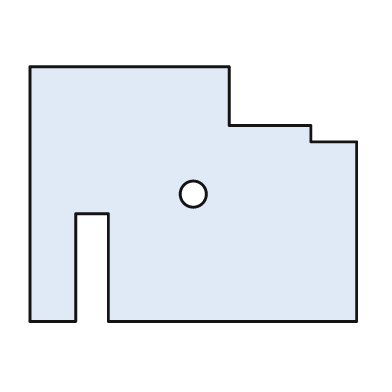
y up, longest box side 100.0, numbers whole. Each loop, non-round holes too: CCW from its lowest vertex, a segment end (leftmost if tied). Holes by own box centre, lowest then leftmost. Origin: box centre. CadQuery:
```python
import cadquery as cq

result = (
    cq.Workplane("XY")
    .moveTo(-50.0, -39.0)
    .lineTo(-36.0, -39.0)
    .lineTo(-36.0, -6.0)
    .lineTo(-26.0, -6.0)
    .lineTo(-26.0, -39.0)
    .lineTo(50.0, -39.0)
    .lineTo(50.0, 16.0)
    .lineTo(36.0, 16.0)
    .lineTo(36.0, 21.0)
    .lineTo(11.0, 21.0)
    .lineTo(11.0, 39.0)
    .lineTo(-50.0, 39.0)
    .close()
    .moveTo(0.0, 0.0)
    .circle(4.0)
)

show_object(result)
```